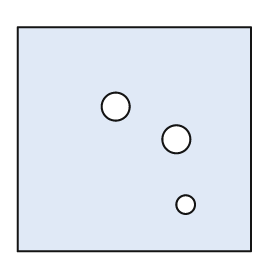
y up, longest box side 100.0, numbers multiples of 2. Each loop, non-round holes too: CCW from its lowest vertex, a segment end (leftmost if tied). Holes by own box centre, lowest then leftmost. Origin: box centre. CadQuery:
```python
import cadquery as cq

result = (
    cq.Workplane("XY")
    .moveTo(-50.0, -48.0)
    .lineTo(50.0, -48.0)
    .lineTo(50.0, 48.0)
    .lineTo(-50.0, 48.0)
    .close()
    .moveTo(22.0, -28.0)
    .circle(4.0)
    .moveTo(18.0, 0.0)
    .circle(6.0)
    .moveTo(-8.0, 14.0)
    .circle(6.0)
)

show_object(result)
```